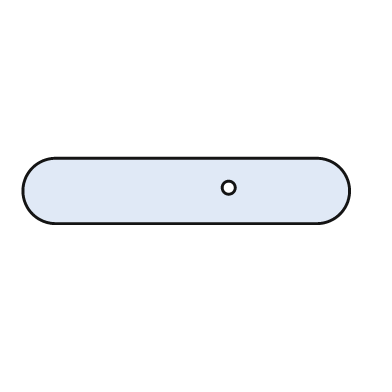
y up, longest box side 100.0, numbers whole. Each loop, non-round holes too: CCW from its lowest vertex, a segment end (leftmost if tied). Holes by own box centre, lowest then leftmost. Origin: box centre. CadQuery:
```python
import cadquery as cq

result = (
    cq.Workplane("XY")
    .moveTo(-40.0, -10.0)
    .lineTo(40.0, -10.0)
    .threePointArc((50.0, 0.0), (40.0, 10.0))
    .lineTo(-40.0, 10.0)
    .threePointArc((-50.0, 0.0), (-40.0, -10.0))
    .close()
    .moveTo(13.0, 1.0)
    .circle(2.0)
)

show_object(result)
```